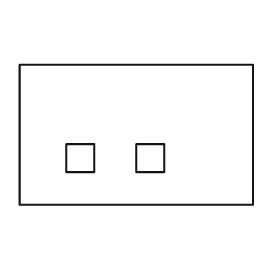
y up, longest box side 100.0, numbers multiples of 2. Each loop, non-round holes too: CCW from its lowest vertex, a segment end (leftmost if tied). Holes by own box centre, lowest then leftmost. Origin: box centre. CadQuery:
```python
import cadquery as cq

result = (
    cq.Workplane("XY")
    .moveTo(-50.0, -30.0)
    .lineTo(50.0, -30.0)
    .lineTo(50.0, 30.0)
    .lineTo(-50.0, 30.0)
    .close()
    .moveTo(-30.0, -16.0)
    .lineTo(-18.0, -16.0)
    .lineTo(-18.0, -4.0)
    .lineTo(-30.0, -4.0)
    .close()
    .moveTo(0.0, -16.0)
    .lineTo(12.0, -16.0)
    .lineTo(12.0, -4.0)
    .lineTo(0.0, -4.0)
    .close()
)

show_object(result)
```